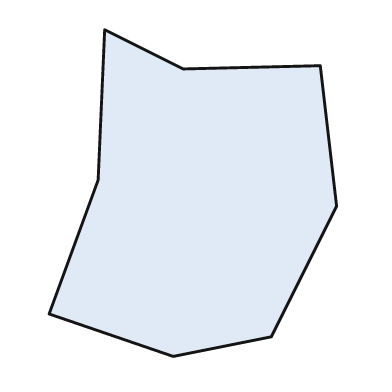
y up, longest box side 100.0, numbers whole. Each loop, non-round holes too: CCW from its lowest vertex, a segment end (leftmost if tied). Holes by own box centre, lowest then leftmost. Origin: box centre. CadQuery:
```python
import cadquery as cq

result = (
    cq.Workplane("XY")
    .moveTo(-6.0, -50.0)
    .lineTo(24.0, -44.0)
    .lineTo(44.0, -4.0)
    .lineTo(39.0, 39.0)
    .lineTo(-3.0, 38.0)
    .lineTo(-27.0, 50.0)
    .lineTo(-29.0, 4.0)
    .lineTo(-44.0, -37.0)
    .close()
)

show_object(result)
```